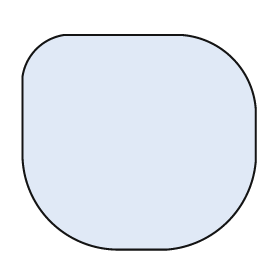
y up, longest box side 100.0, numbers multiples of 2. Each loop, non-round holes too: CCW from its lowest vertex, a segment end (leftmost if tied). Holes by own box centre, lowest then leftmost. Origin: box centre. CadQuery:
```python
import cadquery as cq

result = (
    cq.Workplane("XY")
    .moveTo(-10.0, -46.0)
    .lineTo(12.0, -46.0)
    .threePointArc((38.0, -34.0), (50.0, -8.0))
    .lineTo(50.0, 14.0)
    .threePointArc((40.0, 36.0), (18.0, 46.0))
    .lineTo(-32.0, 46.0)
    .threePointArc((-44.0, 40.0), (-50.0, 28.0))
    .lineTo(-50.0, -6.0)
    .threePointArc((-38.0, -34.0), (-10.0, -46.0))
    .close()
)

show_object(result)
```